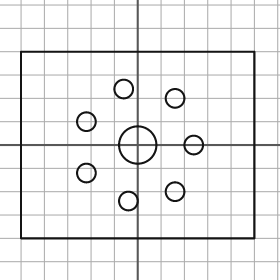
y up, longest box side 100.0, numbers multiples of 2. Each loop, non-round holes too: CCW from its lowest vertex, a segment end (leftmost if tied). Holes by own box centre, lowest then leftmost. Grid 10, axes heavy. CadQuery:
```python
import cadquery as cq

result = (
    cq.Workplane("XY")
    .moveTo(-50.0, -40.0)
    .lineTo(50.0, -40.0)
    .lineTo(50.0, 40.0)
    .lineTo(-50.0, 40.0)
    .close()
    .moveTo(-4.0, -24.0)
    .circle(4.0)
    .moveTo(16.0, -20.0)
    .circle(4.0)
    .moveTo(-22.0, -12.0)
    .circle(4.0)
    .moveTo(0.0, 0.0)
    .circle(8.0)
    .moveTo(24.0, 0.0)
    .circle(4.0)
    .moveTo(-22.0, 10.0)
    .circle(4.0)
    .moveTo(16.0, 20.0)
    .circle(4.0)
    .moveTo(-6.0, 24.0)
    .circle(4.0)
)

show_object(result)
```